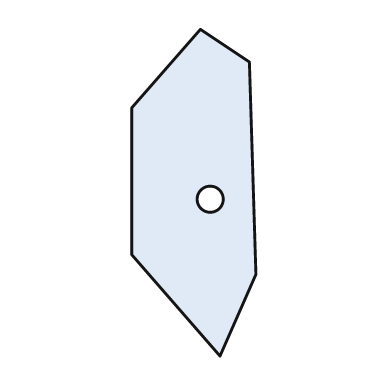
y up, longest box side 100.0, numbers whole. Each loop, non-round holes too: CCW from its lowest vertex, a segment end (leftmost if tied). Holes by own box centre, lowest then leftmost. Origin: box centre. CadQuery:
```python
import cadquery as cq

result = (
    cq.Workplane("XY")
    .moveTo(8.0, -50.0)
    .lineTo(19.0, -25.0)
    .lineTo(17.0, 40.0)
    .lineTo(2.0, 50.0)
    .lineTo(-19.0, 26.0)
    .lineTo(-19.0, -19.0)
    .close()
    .moveTo(5.0, -2.0)
    .circle(4.0)
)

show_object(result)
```